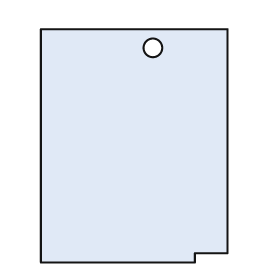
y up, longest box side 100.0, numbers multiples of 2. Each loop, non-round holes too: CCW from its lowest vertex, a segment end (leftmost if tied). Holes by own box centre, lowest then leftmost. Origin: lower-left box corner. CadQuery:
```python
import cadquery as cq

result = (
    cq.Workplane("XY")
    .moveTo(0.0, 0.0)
    .lineTo(66.0, 0.0)
    .lineTo(66.0, 4.0)
    .lineTo(80.0, 4.0)
    .lineTo(80.0, 100.0)
    .lineTo(0.0, 100.0)
    .close()
    .moveTo(48.0, 92.0)
    .circle(4.0)
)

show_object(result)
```